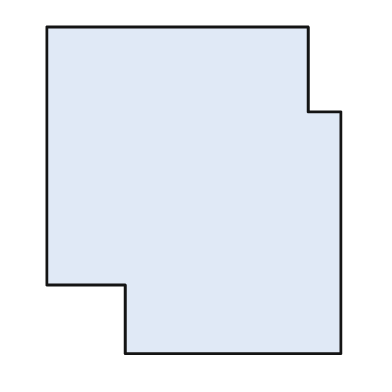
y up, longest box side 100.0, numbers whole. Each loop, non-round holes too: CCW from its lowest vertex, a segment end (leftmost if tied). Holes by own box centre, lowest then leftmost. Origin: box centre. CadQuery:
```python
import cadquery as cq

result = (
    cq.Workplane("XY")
    .moveTo(-21.0, -50.0)
    .lineTo(45.0, -50.0)
    .lineTo(45.0, 24.0)
    .lineTo(35.0, 24.0)
    .lineTo(35.0, 50.0)
    .lineTo(-45.0, 50.0)
    .lineTo(-45.0, -29.0)
    .lineTo(-21.0, -29.0)
    .close()
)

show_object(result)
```